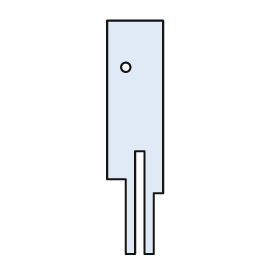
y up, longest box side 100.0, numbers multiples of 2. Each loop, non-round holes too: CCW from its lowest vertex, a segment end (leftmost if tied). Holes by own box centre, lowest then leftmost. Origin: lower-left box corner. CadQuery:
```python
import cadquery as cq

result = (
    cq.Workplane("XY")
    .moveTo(8.0, 0.0)
    .lineTo(12.0, 0.0)
    .lineTo(12.0, 44.0)
    .lineTo(16.0, 44.0)
    .lineTo(16.0, 0.0)
    .lineTo(20.0, 0.0)
    .lineTo(20.0, 26.0)
    .lineTo(24.0, 26.0)
    .lineTo(24.0, 100.0)
    .lineTo(0.0, 100.0)
    .lineTo(0.0, 32.0)
    .lineTo(8.0, 32.0)
    .close()
    .moveTo(8.0, 80.0)
    .circle(2.0)
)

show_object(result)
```